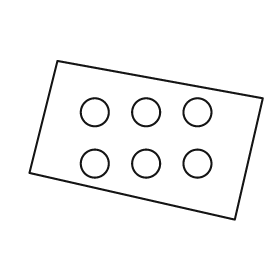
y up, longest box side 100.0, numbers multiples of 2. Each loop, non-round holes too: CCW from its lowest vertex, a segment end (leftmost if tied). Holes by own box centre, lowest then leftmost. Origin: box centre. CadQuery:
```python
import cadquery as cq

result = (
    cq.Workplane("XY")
    .moveTo(38.0, -34.0)
    .lineTo(50.0, 18.0)
    .lineTo(-38.0, 34.0)
    .lineTo(-50.0, -14.0)
    .close()
    .moveTo(-22.0, -10.0)
    .circle(6.0)
    .moveTo(0.0, -10.0)
    .circle(6.0)
    .moveTo(22.0, -10.0)
    .circle(6.0)
    .moveTo(-22.0, 12.0)
    .circle(6.0)
    .moveTo(0.0, 12.0)
    .circle(6.0)
    .moveTo(22.0, 12.0)
    .circle(6.0)
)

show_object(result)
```